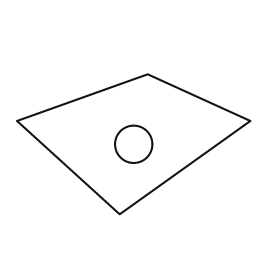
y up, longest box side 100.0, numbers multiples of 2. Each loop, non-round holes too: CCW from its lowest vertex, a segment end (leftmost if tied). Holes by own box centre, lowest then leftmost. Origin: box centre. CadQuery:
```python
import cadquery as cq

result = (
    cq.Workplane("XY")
    .moveTo(-6.0, -30.0)
    .lineTo(50.0, 10.0)
    .lineTo(6.0, 30.0)
    .lineTo(-50.0, 10.0)
    .close()
    .moveTo(0.0, 0.0)
    .circle(8.0)
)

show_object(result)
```